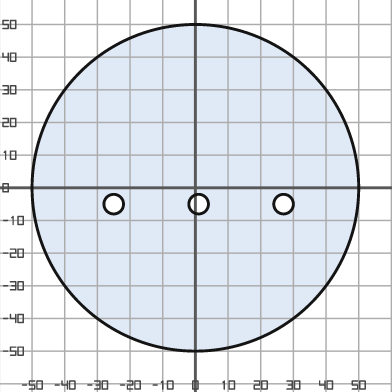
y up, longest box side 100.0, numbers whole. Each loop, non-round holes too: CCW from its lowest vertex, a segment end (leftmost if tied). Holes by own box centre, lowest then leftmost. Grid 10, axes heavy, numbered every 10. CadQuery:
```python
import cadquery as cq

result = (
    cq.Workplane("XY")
    .moveTo(0.0, 0.0)
    .circle(50.0)
    .moveTo(-25.0, -5.0)
    .circle(3.0)
    .moveTo(1.0, -5.0)
    .circle(3.0)
    .moveTo(27.0, -5.0)
    .circle(3.0)
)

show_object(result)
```